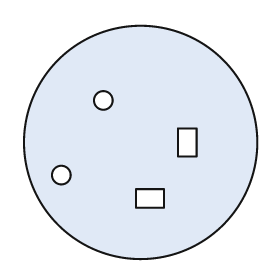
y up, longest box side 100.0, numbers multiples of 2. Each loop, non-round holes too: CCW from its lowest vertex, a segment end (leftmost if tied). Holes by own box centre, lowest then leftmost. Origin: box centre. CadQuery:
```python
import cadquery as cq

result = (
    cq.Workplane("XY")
    .moveTo(0.0, 0.0)
    .circle(50.0)
    .moveTo(-2.0, -28.0)
    .lineTo(10.0, -28.0)
    .lineTo(10.0, -20.0)
    .lineTo(-2.0, -20.0)
    .close()
    .moveTo(-34.0, -14.0)
    .circle(4.0)
    .moveTo(16.0, -6.0)
    .lineTo(24.0, -6.0)
    .lineTo(24.0, 6.0)
    .lineTo(16.0, 6.0)
    .close()
    .moveTo(-16.0, 18.0)
    .circle(4.0)
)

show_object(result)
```